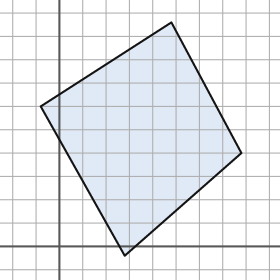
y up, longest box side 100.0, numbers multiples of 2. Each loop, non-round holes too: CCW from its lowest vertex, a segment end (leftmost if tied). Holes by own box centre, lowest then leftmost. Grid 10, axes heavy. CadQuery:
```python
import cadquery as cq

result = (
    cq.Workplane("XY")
    .moveTo(28.0, -4.0)
    .lineTo(78.0, 40.0)
    .lineTo(48.0, 96.0)
    .lineTo(-8.0, 60.0)
    .close()
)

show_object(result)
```